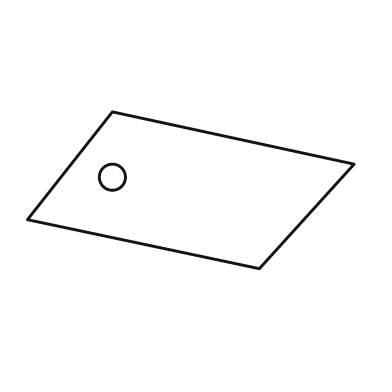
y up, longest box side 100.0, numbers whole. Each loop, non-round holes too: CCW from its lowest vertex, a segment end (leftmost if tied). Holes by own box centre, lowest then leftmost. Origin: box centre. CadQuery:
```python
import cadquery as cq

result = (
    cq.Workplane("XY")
    .moveTo(21.0, -24.0)
    .lineTo(50.0, 8.0)
    .lineTo(-24.0, 24.0)
    .lineTo(-50.0, -9.0)
    .close()
    .moveTo(-24.0, 4.0)
    .circle(4.0)
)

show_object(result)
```